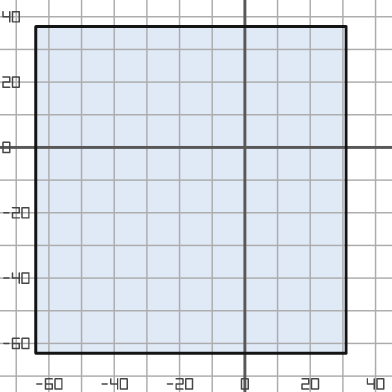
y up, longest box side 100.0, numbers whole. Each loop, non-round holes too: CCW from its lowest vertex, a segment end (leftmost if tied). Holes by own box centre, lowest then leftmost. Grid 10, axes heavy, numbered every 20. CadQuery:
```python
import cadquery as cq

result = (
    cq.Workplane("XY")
    .moveTo(-64.0, -63.0)
    .lineTo(31.0, -63.0)
    .lineTo(31.0, 37.0)
    .lineTo(-64.0, 37.0)
    .close()
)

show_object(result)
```